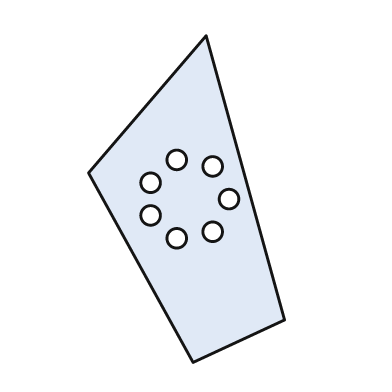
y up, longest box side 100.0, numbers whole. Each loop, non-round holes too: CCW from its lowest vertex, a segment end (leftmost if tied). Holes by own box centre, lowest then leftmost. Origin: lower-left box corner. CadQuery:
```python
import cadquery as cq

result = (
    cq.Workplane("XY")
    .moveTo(32.0, 0.0)
    .lineTo(60.0, 13.0)
    .lineTo(36.0, 100.0)
    .lineTo(0.0, 58.0)
    .close()
    .moveTo(27.0, 38.0)
    .circle(3.0)
    .moveTo(38.0, 40.0)
    .circle(3.0)
    .moveTo(19.0, 45.0)
    .circle(3.0)
    .moveTo(43.0, 50.0)
    .circle(3.0)
    .moveTo(19.0, 55.0)
    .circle(3.0)
    .moveTo(38.0, 60.0)
    .circle(3.0)
    .moveTo(27.0, 62.0)
    .circle(3.0)
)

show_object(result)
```